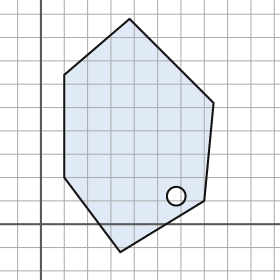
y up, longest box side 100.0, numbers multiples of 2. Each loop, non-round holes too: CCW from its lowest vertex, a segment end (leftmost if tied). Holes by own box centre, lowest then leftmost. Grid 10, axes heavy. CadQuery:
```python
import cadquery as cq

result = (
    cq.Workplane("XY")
    .moveTo(34.0, -12.0)
    .lineTo(70.0, 10.0)
    .lineTo(74.0, 52.0)
    .lineTo(38.0, 88.0)
    .lineTo(10.0, 64.0)
    .lineTo(10.0, 20.0)
    .close()
    .moveTo(58.0, 12.0)
    .circle(4.0)
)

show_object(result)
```